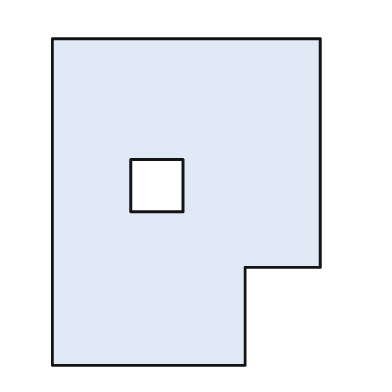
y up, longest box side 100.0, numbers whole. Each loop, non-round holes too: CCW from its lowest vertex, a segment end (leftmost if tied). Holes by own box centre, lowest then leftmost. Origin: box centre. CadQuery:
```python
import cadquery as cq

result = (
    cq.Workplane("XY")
    .moveTo(-41.0, -50.0)
    .lineTo(18.0, -50.0)
    .lineTo(18.0, -20.0)
    .lineTo(41.0, -20.0)
    .lineTo(41.0, 50.0)
    .lineTo(-41.0, 50.0)
    .close()
    .moveTo(-17.0, -3.0)
    .lineTo(-1.0, -3.0)
    .lineTo(-1.0, 13.0)
    .lineTo(-17.0, 13.0)
    .close()
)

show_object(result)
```